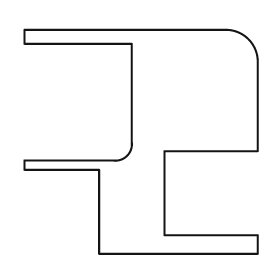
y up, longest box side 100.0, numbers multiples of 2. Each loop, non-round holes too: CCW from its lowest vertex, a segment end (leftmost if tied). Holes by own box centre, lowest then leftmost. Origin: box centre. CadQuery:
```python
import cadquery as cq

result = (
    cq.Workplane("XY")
    .moveTo(-18.0, -48.0)
    .lineTo(50.0, -48.0)
    .lineTo(50.0, -40.0)
    .lineTo(10.0, -40.0)
    .lineTo(10.0, -4.0)
    .lineTo(50.0, -4.0)
    .lineTo(50.0, 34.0)
    .threePointArc((46.0, 44.0), (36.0, 48.0))
    .lineTo(-50.0, 48.0)
    .lineTo(-50.0, 42.0)
    .lineTo(-4.0, 42.0)
    .lineTo(-4.0, 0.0)
    .threePointArc((-6.0, -6.0), (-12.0, -8.0))
    .lineTo(-50.0, -8.0)
    .lineTo(-50.0, -12.0)
    .lineTo(-18.0, -12.0)
    .close()
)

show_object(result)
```